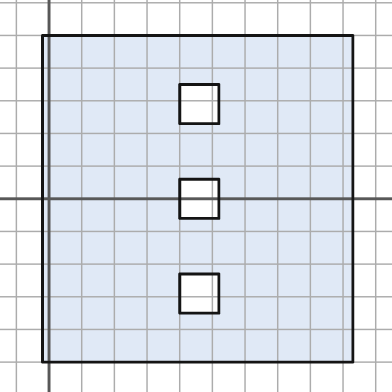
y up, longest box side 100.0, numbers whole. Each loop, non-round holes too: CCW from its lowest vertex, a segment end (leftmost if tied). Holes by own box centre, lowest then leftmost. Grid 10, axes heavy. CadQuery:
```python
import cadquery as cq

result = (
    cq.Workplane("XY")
    .moveTo(-2.0, -50.0)
    .lineTo(93.0, -50.0)
    .lineTo(93.0, 50.0)
    .lineTo(-2.0, 50.0)
    .close()
    .moveTo(40.0, -35.0)
    .lineTo(52.0, -35.0)
    .lineTo(52.0, -23.0)
    .lineTo(40.0, -23.0)
    .close()
    .moveTo(40.0, -6.0)
    .lineTo(52.0, -6.0)
    .lineTo(52.0, 6.0)
    .lineTo(40.0, 6.0)
    .close()
    .moveTo(40.0, 23.0)
    .lineTo(52.0, 23.0)
    .lineTo(52.0, 35.0)
    .lineTo(40.0, 35.0)
    .close()
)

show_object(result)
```